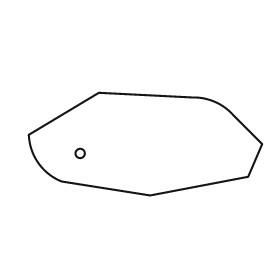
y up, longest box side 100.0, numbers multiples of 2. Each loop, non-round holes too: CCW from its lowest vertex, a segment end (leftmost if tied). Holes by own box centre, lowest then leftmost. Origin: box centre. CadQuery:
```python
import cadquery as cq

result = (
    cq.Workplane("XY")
    .moveTo(2.0, -22.0)
    .lineTo(44.0, -14.0)
    .lineTo(50.0, 0.0)
    .lineTo(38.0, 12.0)
    .threePointArc((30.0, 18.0), (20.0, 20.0))
    .lineTo(-20.0, 22.0)
    .lineTo(-50.0, 4.0)
    .threePointArc((-46.0, -8.0), (-36.0, -16.0))
    .close()
    .moveTo(-28.0, -4.0)
    .circle(2.0)
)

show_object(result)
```